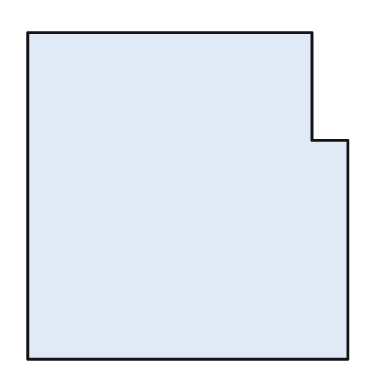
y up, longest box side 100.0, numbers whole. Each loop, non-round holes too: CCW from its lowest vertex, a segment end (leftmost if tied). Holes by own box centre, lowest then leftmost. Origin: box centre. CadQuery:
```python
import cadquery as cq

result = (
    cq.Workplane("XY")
    .moveTo(-49.0, -50.0)
    .lineTo(49.0, -50.0)
    .lineTo(49.0, 17.0)
    .lineTo(38.0, 17.0)
    .lineTo(38.0, 50.0)
    .lineTo(-49.0, 50.0)
    .close()
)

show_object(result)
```